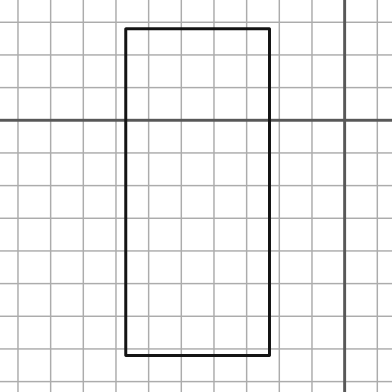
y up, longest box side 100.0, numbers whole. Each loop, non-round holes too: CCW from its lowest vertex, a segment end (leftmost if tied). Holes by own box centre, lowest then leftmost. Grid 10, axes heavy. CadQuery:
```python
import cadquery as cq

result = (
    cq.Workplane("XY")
    .moveTo(-67.0, -72.0)
    .lineTo(-23.0, -72.0)
    .lineTo(-23.0, 28.0)
    .lineTo(-67.0, 28.0)
    .close()
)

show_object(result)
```